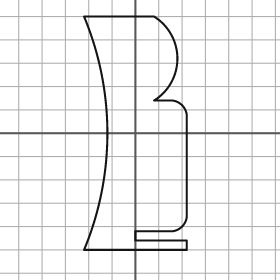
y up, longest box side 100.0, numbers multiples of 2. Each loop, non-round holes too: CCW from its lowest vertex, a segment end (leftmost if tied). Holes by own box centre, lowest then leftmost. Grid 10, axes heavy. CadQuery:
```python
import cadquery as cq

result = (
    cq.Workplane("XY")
    .moveTo(-22.0, -50.0)
    .lineTo(22.0, -50.0)
    .lineTo(22.0, -46.0)
    .lineTo(0.0, -46.0)
    .lineTo(0.0, -42.0)
    .lineTo(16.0, -42.0)
    .threePointArc((20.0, -40.0), (22.0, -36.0))
    .lineTo(22.0, 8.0)
    .threePointArc((20.0, 12.0), (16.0, 14.0))
    .lineTo(8.0, 14.0)
    .threePointArc((18.0, 32.0), (8.0, 50.0))
    .lineTo(-22.0, 50.0)
    .threePointArc((-12.0, 0.0), (-22.0, -50.0))
    .close()
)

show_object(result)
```